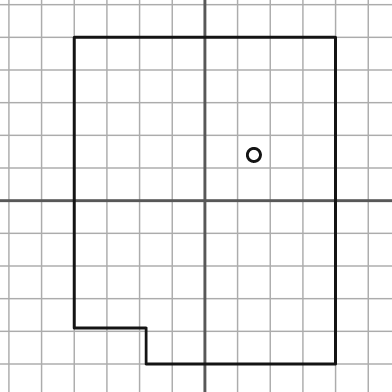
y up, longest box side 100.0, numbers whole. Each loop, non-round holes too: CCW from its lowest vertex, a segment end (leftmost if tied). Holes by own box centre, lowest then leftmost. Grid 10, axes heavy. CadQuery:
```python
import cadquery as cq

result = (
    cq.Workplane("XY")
    .moveTo(-18.0, -50.0)
    .lineTo(40.0, -50.0)
    .lineTo(40.0, 50.0)
    .lineTo(-40.0, 50.0)
    .lineTo(-40.0, -39.0)
    .lineTo(-18.0, -39.0)
    .close()
    .moveTo(15.0, 14.0)
    .circle(2.0)
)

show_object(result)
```